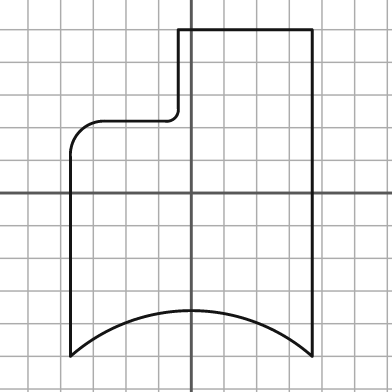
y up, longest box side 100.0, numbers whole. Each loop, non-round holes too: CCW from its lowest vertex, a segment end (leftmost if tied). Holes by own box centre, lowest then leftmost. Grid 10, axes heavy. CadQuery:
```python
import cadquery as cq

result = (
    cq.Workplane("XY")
    .moveTo(-37.0, -50.0)
    .threePointArc((0.0, -36.0), (37.0, -50.0))
    .lineTo(37.0, 50.0)
    .lineTo(-4.0, 50.0)
    .lineTo(-4.0, 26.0)
    .threePointArc((-5.0, 23.0), (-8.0, 22.0))
    .lineTo(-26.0, 22.0)
    .threePointArc((-34.0, 19.0), (-37.0, 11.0))
    .close()
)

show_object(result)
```